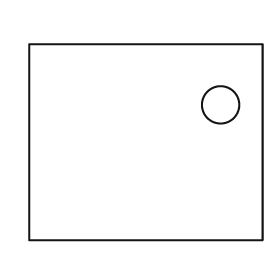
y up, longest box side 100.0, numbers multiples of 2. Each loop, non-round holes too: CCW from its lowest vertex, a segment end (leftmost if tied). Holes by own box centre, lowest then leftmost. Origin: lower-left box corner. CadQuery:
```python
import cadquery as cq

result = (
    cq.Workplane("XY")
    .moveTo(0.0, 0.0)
    .lineTo(100.0, 0.0)
    .lineTo(100.0, 84.0)
    .lineTo(0.0, 84.0)
    .close()
    .moveTo(82.0, 58.0)
    .circle(8.0)
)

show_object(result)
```